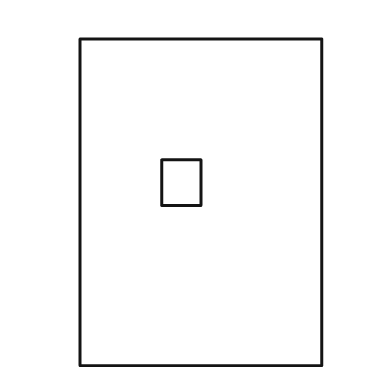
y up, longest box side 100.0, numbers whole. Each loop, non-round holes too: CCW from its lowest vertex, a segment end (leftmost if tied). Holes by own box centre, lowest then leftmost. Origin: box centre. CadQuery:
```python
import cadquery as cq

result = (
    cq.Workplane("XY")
    .moveTo(-37.0, -50.0)
    .lineTo(37.0, -50.0)
    .lineTo(37.0, 50.0)
    .lineTo(-37.0, 50.0)
    .close()
    .moveTo(-12.0, -1.0)
    .lineTo(0.0, -1.0)
    .lineTo(0.0, 13.0)
    .lineTo(-12.0, 13.0)
    .close()
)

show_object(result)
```